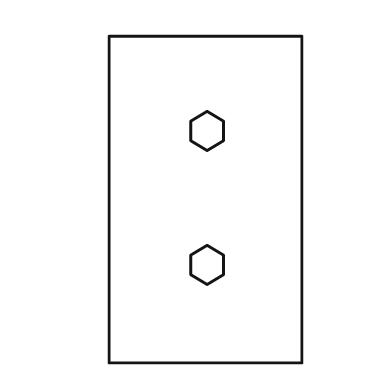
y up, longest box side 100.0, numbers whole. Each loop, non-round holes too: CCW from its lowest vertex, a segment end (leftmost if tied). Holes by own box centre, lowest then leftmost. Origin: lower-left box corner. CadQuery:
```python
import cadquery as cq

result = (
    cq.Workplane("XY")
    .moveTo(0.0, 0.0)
    .lineTo(59.0, 0.0)
    .lineTo(59.0, 100.0)
    .lineTo(0.0, 100.0)
    .close()
    .moveTo(30.0, 24.0)
    .lineTo(35.0, 27.0)
    .lineTo(35.0, 33.0)
    .lineTo(30.0, 36.0)
    .lineTo(25.0, 33.0)
    .lineTo(25.0, 27.0)
    .close()
    .moveTo(30.0, 65.0)
    .lineTo(35.0, 68.0)
    .lineTo(35.0, 74.0)
    .lineTo(30.0, 77.0)
    .lineTo(25.0, 74.0)
    .lineTo(25.0, 68.0)
    .close()
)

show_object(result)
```